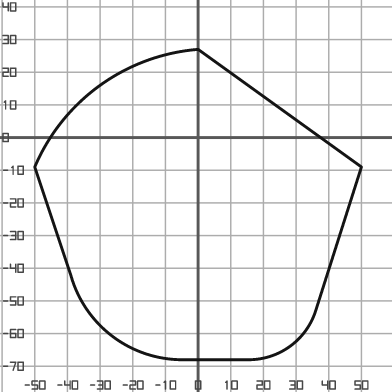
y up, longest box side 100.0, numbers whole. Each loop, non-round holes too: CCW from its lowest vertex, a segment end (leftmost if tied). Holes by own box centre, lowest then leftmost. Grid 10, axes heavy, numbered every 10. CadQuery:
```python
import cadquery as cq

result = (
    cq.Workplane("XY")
    .moveTo(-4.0, -68.0)
    .lineTo(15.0, -68.0)
    .threePointArc((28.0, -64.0), (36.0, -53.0))
    .lineTo(50.0, -9.0)
    .lineTo(0.0, 27.0)
    .threePointArc((-30.0, 16.0), (-50.0, -9.0))
    .lineTo(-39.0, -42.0)
    .threePointArc((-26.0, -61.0), (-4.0, -68.0))
    .close()
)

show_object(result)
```